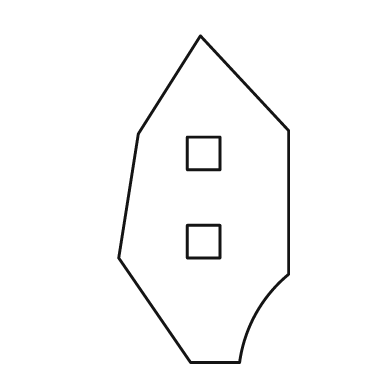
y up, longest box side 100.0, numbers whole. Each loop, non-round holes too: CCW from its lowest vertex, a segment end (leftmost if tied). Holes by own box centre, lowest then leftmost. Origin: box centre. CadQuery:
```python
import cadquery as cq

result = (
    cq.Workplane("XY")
    .moveTo(-4.0, -50.0)
    .lineTo(11.0, -50.0)
    .threePointArc((16.0, -35.0), (26.0, -23.0))
    .lineTo(26.0, 21.0)
    .lineTo(-1.0, 50.0)
    .lineTo(-20.0, 20.0)
    .lineTo(-26.0, -18.0)
    .close()
    .moveTo(-5.0, -18.0)
    .lineTo(5.0, -18.0)
    .lineTo(5.0, -8.0)
    .lineTo(-5.0, -8.0)
    .close()
    .moveTo(-5.0, 9.0)
    .lineTo(5.0, 9.0)
    .lineTo(5.0, 19.0)
    .lineTo(-5.0, 19.0)
    .close()
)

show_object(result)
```